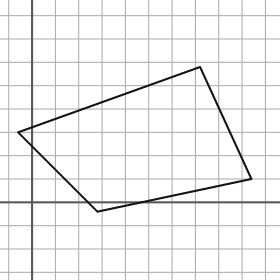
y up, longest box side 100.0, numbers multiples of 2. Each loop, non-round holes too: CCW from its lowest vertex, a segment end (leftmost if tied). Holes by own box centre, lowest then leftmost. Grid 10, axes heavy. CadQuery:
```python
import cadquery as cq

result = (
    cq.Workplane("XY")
    .moveTo(28.0, -4.0)
    .lineTo(94.0, 10.0)
    .lineTo(72.0, 58.0)
    .lineTo(-6.0, 30.0)
    .close()
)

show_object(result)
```